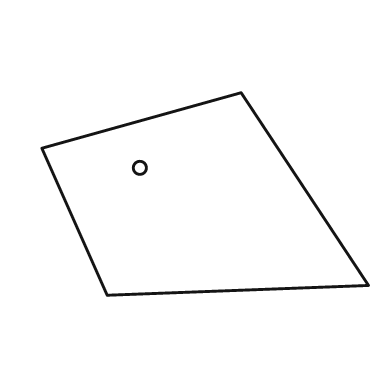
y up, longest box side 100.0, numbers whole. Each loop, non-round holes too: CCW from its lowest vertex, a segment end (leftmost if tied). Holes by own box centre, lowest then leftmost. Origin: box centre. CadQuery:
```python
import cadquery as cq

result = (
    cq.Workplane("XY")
    .moveTo(-30.0, -31.0)
    .lineTo(50.0, -28.0)
    .lineTo(11.0, 31.0)
    .lineTo(-50.0, 14.0)
    .close()
    .moveTo(-20.0, 8.0)
    .circle(2.0)
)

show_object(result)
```